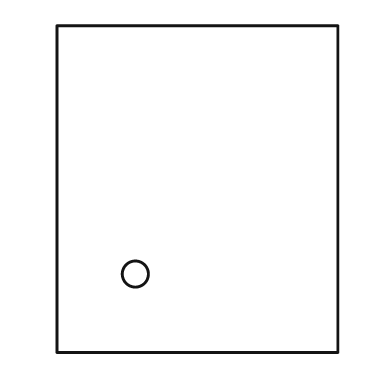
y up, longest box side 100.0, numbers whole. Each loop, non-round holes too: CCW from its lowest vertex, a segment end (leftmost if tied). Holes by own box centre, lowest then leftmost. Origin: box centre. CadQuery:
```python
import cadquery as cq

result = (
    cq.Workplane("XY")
    .moveTo(-43.0, -50.0)
    .lineTo(43.0, -50.0)
    .lineTo(43.0, 50.0)
    .lineTo(-43.0, 50.0)
    .close()
    .moveTo(-19.0, -26.0)
    .circle(4.0)
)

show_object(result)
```